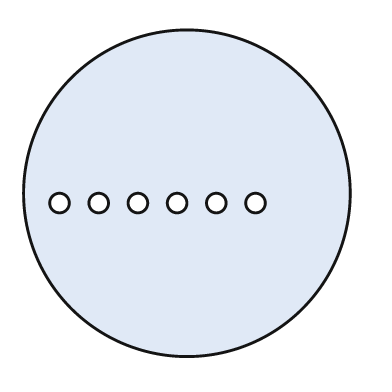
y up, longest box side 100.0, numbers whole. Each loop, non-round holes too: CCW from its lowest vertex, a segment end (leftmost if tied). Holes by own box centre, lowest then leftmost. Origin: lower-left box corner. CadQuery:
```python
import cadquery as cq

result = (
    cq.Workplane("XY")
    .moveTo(50.0, 50.0)
    .circle(50.0)
    .moveTo(11.0, 47.0)
    .circle(3.0)
    .moveTo(23.0, 47.0)
    .circle(3.0)
    .moveTo(35.0, 47.0)
    .circle(3.0)
    .moveTo(47.0, 47.0)
    .circle(3.0)
    .moveTo(59.0, 47.0)
    .circle(3.0)
    .moveTo(71.0, 47.0)
    .circle(3.0)
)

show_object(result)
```